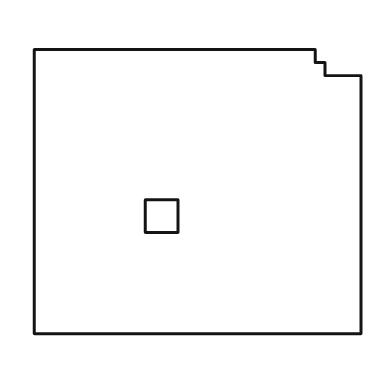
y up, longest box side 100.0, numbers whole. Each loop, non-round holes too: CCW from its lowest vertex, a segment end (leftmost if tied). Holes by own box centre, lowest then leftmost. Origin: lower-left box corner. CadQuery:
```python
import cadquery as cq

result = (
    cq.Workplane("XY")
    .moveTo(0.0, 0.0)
    .lineTo(100.0, 0.0)
    .lineTo(100.0, 79.0)
    .lineTo(89.0, 79.0)
    .lineTo(89.0, 83.0)
    .lineTo(86.0, 83.0)
    .lineTo(86.0, 87.0)
    .lineTo(0.0, 87.0)
    .close()
    .moveTo(34.0, 31.0)
    .lineTo(44.0, 31.0)
    .lineTo(44.0, 41.0)
    .lineTo(34.0, 41.0)
    .close()
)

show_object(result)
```